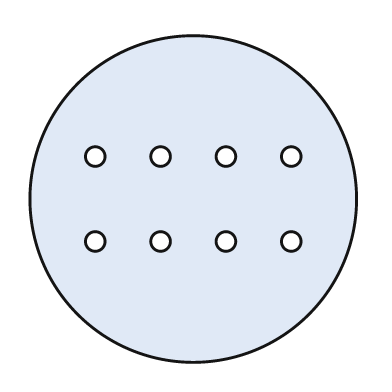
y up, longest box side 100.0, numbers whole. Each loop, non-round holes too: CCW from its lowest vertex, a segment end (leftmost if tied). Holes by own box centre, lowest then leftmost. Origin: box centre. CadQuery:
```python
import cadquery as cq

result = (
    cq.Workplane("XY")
    .moveTo(0.0, 0.0)
    .circle(50.0)
    .moveTo(-30.0, -13.0)
    .circle(3.0)
    .moveTo(-10.0, -13.0)
    .circle(3.0)
    .moveTo(10.0, -13.0)
    .circle(3.0)
    .moveTo(30.0, -13.0)
    .circle(3.0)
    .moveTo(-30.0, 13.0)
    .circle(3.0)
    .moveTo(-10.0, 13.0)
    .circle(3.0)
    .moveTo(10.0, 13.0)
    .circle(3.0)
    .moveTo(30.0, 13.0)
    .circle(3.0)
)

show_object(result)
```